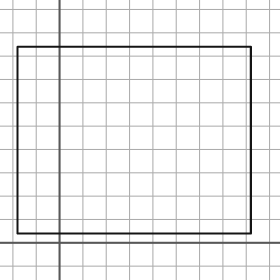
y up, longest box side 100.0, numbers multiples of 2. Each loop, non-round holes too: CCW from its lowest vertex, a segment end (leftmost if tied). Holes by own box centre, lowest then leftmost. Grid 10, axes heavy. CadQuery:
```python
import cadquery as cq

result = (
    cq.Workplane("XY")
    .moveTo(-18.0, 4.0)
    .lineTo(82.0, 4.0)
    .lineTo(82.0, 84.0)
    .lineTo(-18.0, 84.0)
    .close()
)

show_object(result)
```